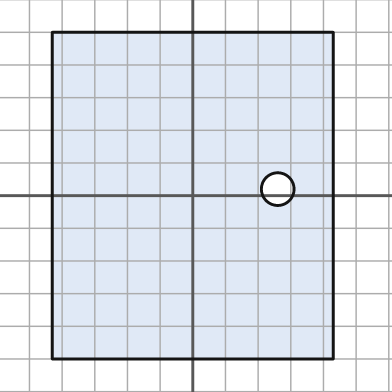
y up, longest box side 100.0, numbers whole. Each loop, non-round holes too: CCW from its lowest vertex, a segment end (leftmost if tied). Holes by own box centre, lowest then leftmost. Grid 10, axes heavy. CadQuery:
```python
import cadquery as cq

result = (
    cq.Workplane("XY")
    .moveTo(-43.0, -50.0)
    .lineTo(43.0, -50.0)
    .lineTo(43.0, 50.0)
    .lineTo(-43.0, 50.0)
    .close()
    .moveTo(26.0, 2.0)
    .circle(5.0)
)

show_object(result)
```